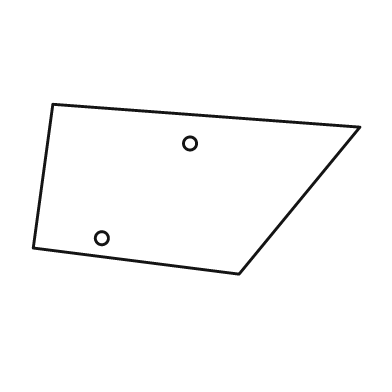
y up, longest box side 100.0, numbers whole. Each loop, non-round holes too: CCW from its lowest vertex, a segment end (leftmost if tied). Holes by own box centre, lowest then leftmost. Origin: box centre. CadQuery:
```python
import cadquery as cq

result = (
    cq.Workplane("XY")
    .moveTo(13.0, -26.0)
    .lineTo(50.0, 19.0)
    .lineTo(-44.0, 26.0)
    .lineTo(-50.0, -18.0)
    .close()
    .moveTo(-29.0, -15.0)
    .circle(2.0)
    .moveTo(-2.0, 14.0)
    .circle(2.0)
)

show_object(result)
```